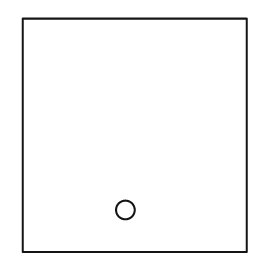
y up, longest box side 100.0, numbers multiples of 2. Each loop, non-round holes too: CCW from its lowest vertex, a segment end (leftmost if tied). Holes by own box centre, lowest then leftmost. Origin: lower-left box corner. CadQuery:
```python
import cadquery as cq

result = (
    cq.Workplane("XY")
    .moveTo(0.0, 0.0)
    .lineTo(96.0, 0.0)
    .lineTo(96.0, 100.0)
    .lineTo(0.0, 100.0)
    .close()
    .moveTo(44.0, 18.0)
    .circle(4.0)
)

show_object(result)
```